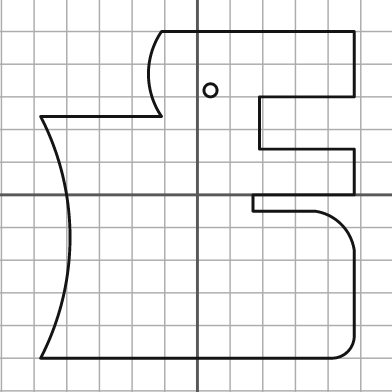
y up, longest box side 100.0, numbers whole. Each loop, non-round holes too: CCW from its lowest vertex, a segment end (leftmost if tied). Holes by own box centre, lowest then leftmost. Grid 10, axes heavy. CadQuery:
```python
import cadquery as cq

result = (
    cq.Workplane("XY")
    .moveTo(-48.0, -50.0)
    .lineTo(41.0, -50.0)
    .threePointArc((46.0, -48.0), (48.0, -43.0))
    .lineTo(48.0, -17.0)
    .threePointArc((44.0, -9.0), (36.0, -5.0))
    .lineTo(17.0, -5.0)
    .lineTo(17.0, 0.0)
    .lineTo(48.0, 0.0)
    .lineTo(48.0, 14.0)
    .lineTo(19.0, 14.0)
    .lineTo(19.0, 30.0)
    .lineTo(48.0, 30.0)
    .lineTo(48.0, 50.0)
    .lineTo(-11.0, 50.0)
    .threePointArc((-15.0, 37.0), (-11.0, 24.0))
    .lineTo(-48.0, 24.0)
    .threePointArc((-39.0, -13.0), (-48.0, -50.0))
    .close()
    .moveTo(4.0, 32.0)
    .circle(2.0)
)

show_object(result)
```